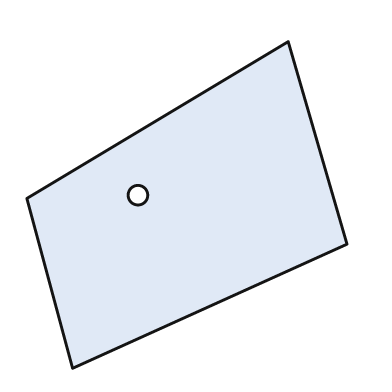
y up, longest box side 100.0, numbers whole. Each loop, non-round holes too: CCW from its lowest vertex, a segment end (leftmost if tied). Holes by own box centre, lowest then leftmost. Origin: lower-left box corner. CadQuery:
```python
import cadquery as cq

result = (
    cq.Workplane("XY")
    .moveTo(14.0, 0.0)
    .lineTo(98.0, 38.0)
    .lineTo(80.0, 100.0)
    .lineTo(0.0, 52.0)
    .close()
    .moveTo(34.0, 53.0)
    .circle(3.0)
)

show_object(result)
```